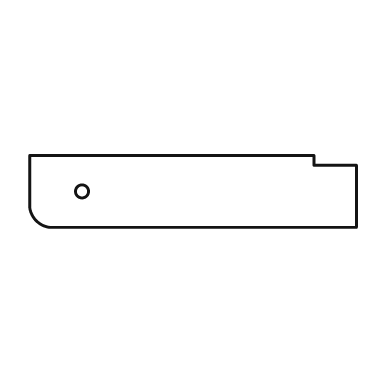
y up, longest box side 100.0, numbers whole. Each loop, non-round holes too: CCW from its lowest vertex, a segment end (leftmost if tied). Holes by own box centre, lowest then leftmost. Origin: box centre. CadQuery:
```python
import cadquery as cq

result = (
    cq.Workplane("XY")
    .moveTo(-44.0, -11.0)
    .lineTo(50.0, -11.0)
    .lineTo(50.0, 8.0)
    .lineTo(37.0, 8.0)
    .lineTo(37.0, 11.0)
    .lineTo(-50.0, 11.0)
    .lineTo(-50.0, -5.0)
    .threePointArc((-48.0, -9.0), (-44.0, -11.0))
    .close()
    .moveTo(-34.0, 0.0)
    .circle(2.0)
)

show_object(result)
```